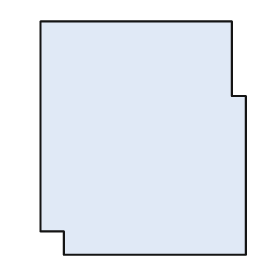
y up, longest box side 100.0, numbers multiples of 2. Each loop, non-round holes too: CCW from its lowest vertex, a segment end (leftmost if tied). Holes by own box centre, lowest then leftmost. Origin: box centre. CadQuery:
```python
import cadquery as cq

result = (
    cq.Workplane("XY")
    .moveTo(-34.0, -50.0)
    .lineTo(44.0, -50.0)
    .lineTo(44.0, 18.0)
    .lineTo(38.0, 18.0)
    .lineTo(38.0, 50.0)
    .lineTo(-44.0, 50.0)
    .lineTo(-44.0, -40.0)
    .lineTo(-34.0, -40.0)
    .close()
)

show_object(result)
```